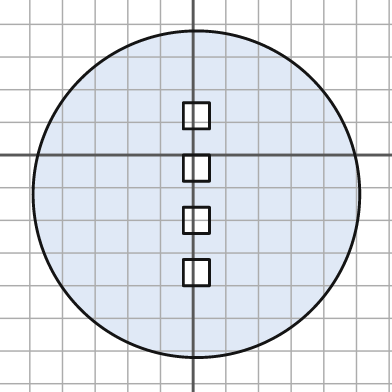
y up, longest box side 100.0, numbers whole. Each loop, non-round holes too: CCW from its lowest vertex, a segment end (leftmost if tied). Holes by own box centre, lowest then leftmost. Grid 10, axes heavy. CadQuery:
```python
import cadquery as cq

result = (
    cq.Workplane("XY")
    .moveTo(1.0, -12.0)
    .circle(50.0)
    .moveTo(-3.0, -40.0)
    .lineTo(5.0, -40.0)
    .lineTo(5.0, -32.0)
    .lineTo(-3.0, -32.0)
    .close()
    .moveTo(-3.0, -24.0)
    .lineTo(5.0, -24.0)
    .lineTo(5.0, -16.0)
    .lineTo(-3.0, -16.0)
    .close()
    .moveTo(-3.0, -8.0)
    .lineTo(5.0, -8.0)
    .lineTo(5.0, 0.0)
    .lineTo(-3.0, 0.0)
    .close()
    .moveTo(-3.0, 8.0)
    .lineTo(5.0, 8.0)
    .lineTo(5.0, 16.0)
    .lineTo(-3.0, 16.0)
    .close()
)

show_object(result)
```